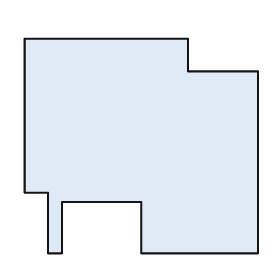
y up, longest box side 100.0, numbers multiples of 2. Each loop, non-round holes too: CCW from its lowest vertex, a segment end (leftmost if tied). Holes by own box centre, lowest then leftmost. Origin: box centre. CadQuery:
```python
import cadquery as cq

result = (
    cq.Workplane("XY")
    .moveTo(-40.0, -46.0)
    .lineTo(-34.0, -46.0)
    .lineTo(-34.0, -24.0)
    .lineTo(0.0, -24.0)
    .lineTo(0.0, -46.0)
    .lineTo(50.0, -46.0)
    .lineTo(50.0, 32.0)
    .lineTo(20.0, 32.0)
    .lineTo(20.0, 46.0)
    .lineTo(-50.0, 46.0)
    .lineTo(-50.0, -20.0)
    .lineTo(-40.0, -20.0)
    .close()
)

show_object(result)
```